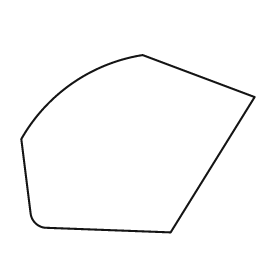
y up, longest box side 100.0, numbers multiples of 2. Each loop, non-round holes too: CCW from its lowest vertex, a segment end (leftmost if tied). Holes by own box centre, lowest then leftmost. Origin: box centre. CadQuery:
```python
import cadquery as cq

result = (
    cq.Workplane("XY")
    .moveTo(14.0, -38.0)
    .lineTo(50.0, 20.0)
    .lineTo(2.0, 38.0)
    .threePointArc((-28.0, 26.0), (-50.0, 2.0))
    .lineTo(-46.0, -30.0)
    .threePointArc((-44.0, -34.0), (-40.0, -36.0))
    .close()
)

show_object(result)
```